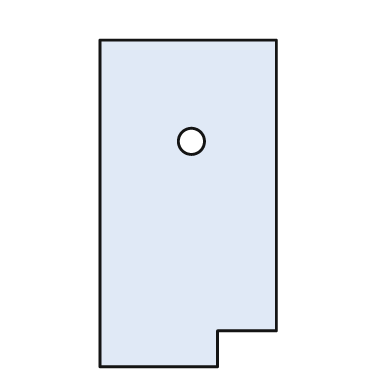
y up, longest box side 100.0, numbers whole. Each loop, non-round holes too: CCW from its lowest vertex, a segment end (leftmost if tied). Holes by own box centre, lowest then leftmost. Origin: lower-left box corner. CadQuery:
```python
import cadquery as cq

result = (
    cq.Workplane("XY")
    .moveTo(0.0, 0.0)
    .lineTo(36.0, 0.0)
    .lineTo(36.0, 11.0)
    .lineTo(54.0, 11.0)
    .lineTo(54.0, 100.0)
    .lineTo(0.0, 100.0)
    .close()
    .moveTo(28.0, 69.0)
    .circle(4.0)
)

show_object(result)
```